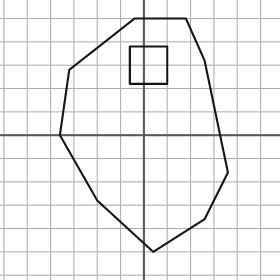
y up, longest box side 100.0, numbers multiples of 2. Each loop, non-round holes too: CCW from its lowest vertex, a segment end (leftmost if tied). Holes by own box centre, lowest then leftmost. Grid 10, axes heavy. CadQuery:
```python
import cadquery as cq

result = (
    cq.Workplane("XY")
    .moveTo(4.0, -50.0)
    .lineTo(26.0, -36.0)
    .lineTo(36.0, -16.0)
    .lineTo(26.0, 32.0)
    .lineTo(18.0, 50.0)
    .lineTo(-4.0, 50.0)
    .lineTo(-32.0, 28.0)
    .lineTo(-36.0, 0.0)
    .lineTo(-20.0, -28.0)
    .close()
    .moveTo(-6.0, 22.0)
    .lineTo(10.0, 22.0)
    .lineTo(10.0, 38.0)
    .lineTo(-6.0, 38.0)
    .close()
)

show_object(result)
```